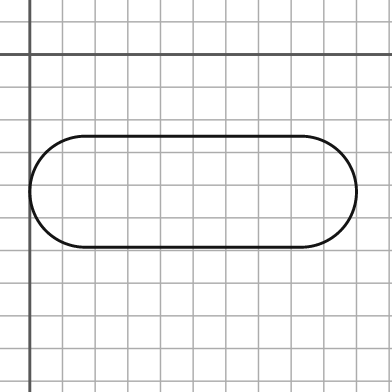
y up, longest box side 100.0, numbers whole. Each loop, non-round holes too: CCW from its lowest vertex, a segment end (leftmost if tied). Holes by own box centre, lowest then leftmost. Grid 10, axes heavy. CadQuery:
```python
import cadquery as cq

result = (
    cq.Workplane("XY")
    .moveTo(17.0, -59.0)
    .lineTo(83.0, -59.0)
    .threePointArc((100.0, -42.0), (83.0, -25.0))
    .lineTo(17.0, -25.0)
    .threePointArc((0.0, -42.0), (17.0, -59.0))
    .close()
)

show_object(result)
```